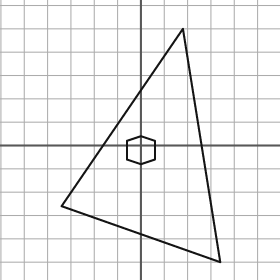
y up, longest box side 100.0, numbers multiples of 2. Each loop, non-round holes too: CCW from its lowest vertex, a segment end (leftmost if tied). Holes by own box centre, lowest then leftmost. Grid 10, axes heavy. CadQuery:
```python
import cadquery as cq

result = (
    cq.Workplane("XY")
    .moveTo(34.0, -50.0)
    .lineTo(18.0, 50.0)
    .lineTo(-34.0, -26.0)
    .close()
    .moveTo(0.0, -8.0)
    .lineTo(6.0, -6.0)
    .lineTo(6.0, 2.0)
    .lineTo(0.0, 4.0)
    .lineTo(-6.0, 2.0)
    .lineTo(-6.0, -6.0)
    .close()
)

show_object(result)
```